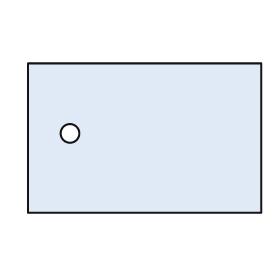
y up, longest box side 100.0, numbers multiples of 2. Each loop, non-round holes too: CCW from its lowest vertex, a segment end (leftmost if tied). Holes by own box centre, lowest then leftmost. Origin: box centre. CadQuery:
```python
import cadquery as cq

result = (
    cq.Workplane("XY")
    .moveTo(-50.0, -32.0)
    .lineTo(50.0, -32.0)
    .lineTo(50.0, 32.0)
    .lineTo(-50.0, 32.0)
    .close()
    .moveTo(-32.0, 2.0)
    .circle(4.0)
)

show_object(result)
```